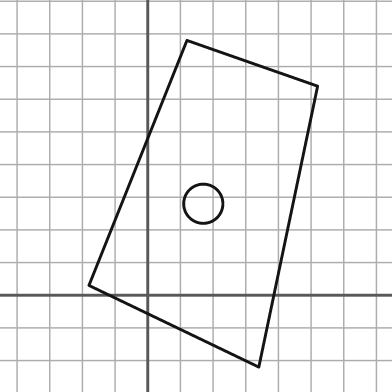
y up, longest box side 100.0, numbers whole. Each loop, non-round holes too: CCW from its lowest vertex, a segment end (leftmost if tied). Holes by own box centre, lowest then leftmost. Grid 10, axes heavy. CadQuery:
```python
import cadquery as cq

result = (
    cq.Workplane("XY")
    .moveTo(34.0, -22.0)
    .lineTo(52.0, 64.0)
    .lineTo(12.0, 78.0)
    .lineTo(-18.0, 3.0)
    .close()
    .moveTo(17.0, 28.0)
    .circle(6.0)
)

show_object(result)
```